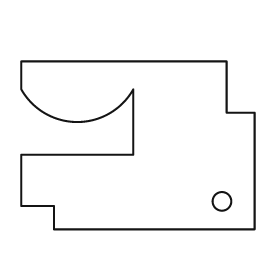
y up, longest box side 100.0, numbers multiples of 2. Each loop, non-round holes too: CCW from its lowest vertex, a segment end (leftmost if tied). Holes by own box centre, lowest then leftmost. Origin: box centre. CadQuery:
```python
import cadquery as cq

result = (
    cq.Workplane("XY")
    .moveTo(-36.0, -36.0)
    .lineTo(50.0, -36.0)
    .lineTo(50.0, 14.0)
    .lineTo(38.0, 14.0)
    .lineTo(38.0, 36.0)
    .lineTo(-50.0, 36.0)
    .lineTo(-50.0, 24.0)
    .threePointArc((-26.0, 10.0), (-2.0, 24.0))
    .lineTo(-2.0, -4.0)
    .lineTo(-50.0, -4.0)
    .lineTo(-50.0, -26.0)
    .lineTo(-36.0, -26.0)
    .close()
    .moveTo(36.0, -24.0)
    .circle(4.0)
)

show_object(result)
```